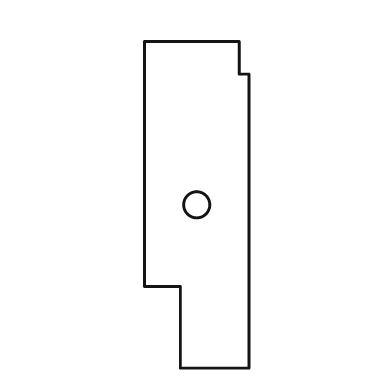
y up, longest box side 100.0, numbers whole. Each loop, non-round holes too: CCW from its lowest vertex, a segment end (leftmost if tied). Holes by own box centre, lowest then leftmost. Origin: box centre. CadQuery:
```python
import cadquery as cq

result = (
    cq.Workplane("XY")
    .moveTo(-5.0, -50.0)
    .lineTo(16.0, -50.0)
    .lineTo(16.0, 40.0)
    .lineTo(13.0, 40.0)
    .lineTo(13.0, 50.0)
    .lineTo(-16.0, 50.0)
    .lineTo(-16.0, -25.0)
    .lineTo(-5.0, -25.0)
    .close()
    .moveTo(0.0, 0.0)
    .circle(4.0)
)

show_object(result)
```